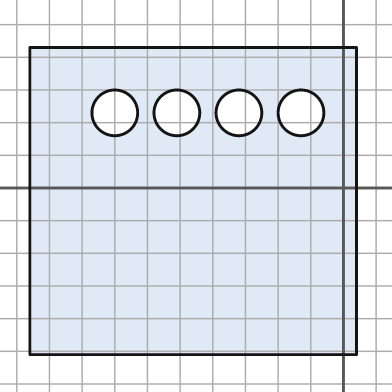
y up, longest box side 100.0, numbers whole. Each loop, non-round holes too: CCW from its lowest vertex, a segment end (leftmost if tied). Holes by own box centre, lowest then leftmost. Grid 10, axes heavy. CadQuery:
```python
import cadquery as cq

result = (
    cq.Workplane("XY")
    .moveTo(-96.0, -51.0)
    .lineTo(4.0, -51.0)
    .lineTo(4.0, 43.0)
    .lineTo(-96.0, 43.0)
    .close()
    .moveTo(-70.0, 23.0)
    .circle(7.0)
    .moveTo(-51.0, 23.0)
    .circle(7.0)
    .moveTo(-32.0, 23.0)
    .circle(7.0)
    .moveTo(-13.0, 23.0)
    .circle(7.0)
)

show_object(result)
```